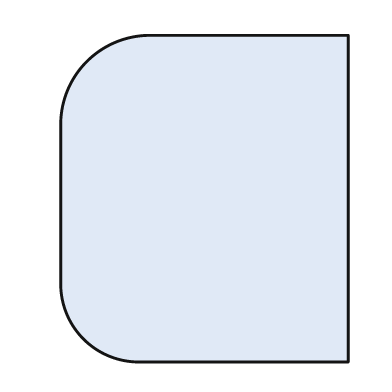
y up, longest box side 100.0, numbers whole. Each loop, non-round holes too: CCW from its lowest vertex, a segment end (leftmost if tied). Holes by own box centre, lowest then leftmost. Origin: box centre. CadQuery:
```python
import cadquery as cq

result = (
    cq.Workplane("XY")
    .moveTo(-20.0, -50.0)
    .lineTo(44.0, -50.0)
    .lineTo(44.0, 50.0)
    .lineTo(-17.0, 50.0)
    .threePointArc((-36.0, 42.0), (-44.0, 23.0))
    .lineTo(-44.0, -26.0)
    .threePointArc((-37.0, -43.0), (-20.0, -50.0))
    .close()
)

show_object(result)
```